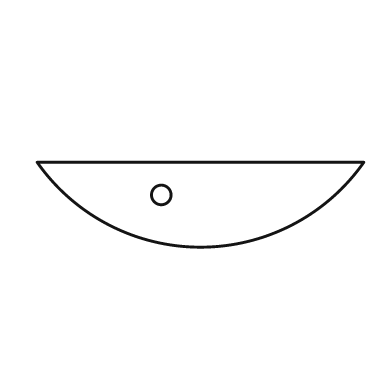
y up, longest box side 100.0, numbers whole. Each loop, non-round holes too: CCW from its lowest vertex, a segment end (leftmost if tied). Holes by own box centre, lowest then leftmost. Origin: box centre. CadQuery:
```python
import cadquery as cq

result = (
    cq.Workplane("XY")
    .moveTo(-50.0, 13.0)
    .threePointArc((0.0, -13.0), (50.0, 13.0))
    .close()
    .moveTo(-12.0, 3.0)
    .circle(3.0)
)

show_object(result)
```